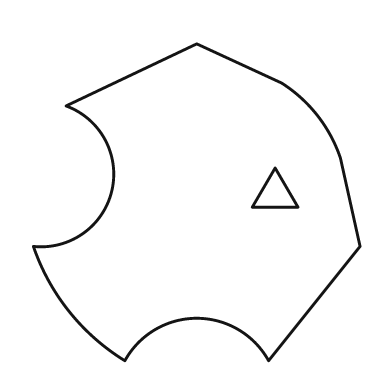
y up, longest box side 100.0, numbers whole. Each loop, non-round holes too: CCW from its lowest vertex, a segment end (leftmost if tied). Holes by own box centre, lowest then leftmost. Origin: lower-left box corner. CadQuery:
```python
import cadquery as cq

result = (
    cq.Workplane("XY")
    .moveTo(28.0, 0.0)
    .threePointArc((50.0, 13.0), (72.0, 0.0))
    .lineTo(100.0, 35.0)
    .lineTo(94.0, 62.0)
    .threePointArc((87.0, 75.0), (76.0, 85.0))
    .lineTo(50.0, 97.0)
    .lineTo(10.0, 78.0)
    .threePointArc((24.0, 52.0), (0.0, 35.0))
    .threePointArc((11.0, 15.0), (28.0, 0.0))
    .close()
    .moveTo(67.0, 47.0)
    .lineTo(81.0, 47.0)
    .lineTo(74.0, 59.0)
    .close()
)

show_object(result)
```